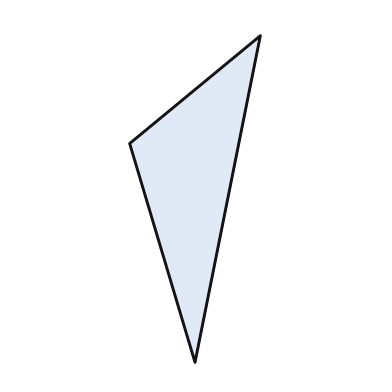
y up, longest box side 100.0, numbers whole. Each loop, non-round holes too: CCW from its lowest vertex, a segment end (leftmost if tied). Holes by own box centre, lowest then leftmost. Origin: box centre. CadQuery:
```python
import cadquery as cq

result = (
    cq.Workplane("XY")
    .moveTo(0.0, -50.0)
    .lineTo(20.0, 50.0)
    .lineTo(-20.0, 17.0)
    .close()
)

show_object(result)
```